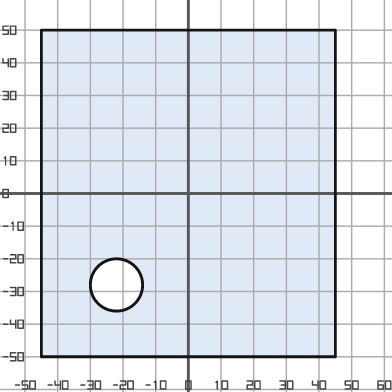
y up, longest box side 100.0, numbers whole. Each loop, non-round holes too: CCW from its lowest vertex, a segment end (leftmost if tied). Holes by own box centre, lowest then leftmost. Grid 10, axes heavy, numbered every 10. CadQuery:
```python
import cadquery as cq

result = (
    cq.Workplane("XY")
    .moveTo(-45.0, -50.0)
    .lineTo(45.0, -50.0)
    .lineTo(45.0, 50.0)
    .lineTo(-45.0, 50.0)
    .close()
    .moveTo(-22.0, -28.0)
    .circle(8.0)
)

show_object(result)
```